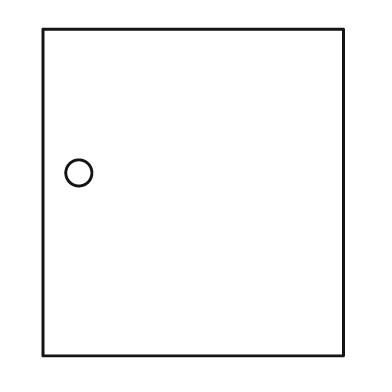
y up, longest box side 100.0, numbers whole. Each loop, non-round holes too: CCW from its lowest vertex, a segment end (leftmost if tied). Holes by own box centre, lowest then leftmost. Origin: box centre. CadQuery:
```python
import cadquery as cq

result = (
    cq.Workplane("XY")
    .moveTo(-46.0, -50.0)
    .lineTo(46.0, -50.0)
    .lineTo(46.0, 50.0)
    .lineTo(-46.0, 50.0)
    .close()
    .moveTo(-35.0, 6.0)
    .circle(4.0)
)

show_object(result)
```